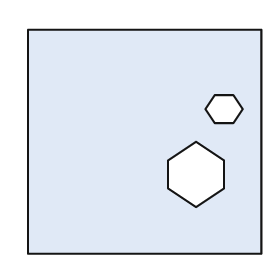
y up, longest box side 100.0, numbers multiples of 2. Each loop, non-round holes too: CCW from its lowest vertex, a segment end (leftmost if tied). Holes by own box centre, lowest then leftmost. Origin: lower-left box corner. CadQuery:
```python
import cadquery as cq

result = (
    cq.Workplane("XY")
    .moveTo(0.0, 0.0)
    .lineTo(100.0, 0.0)
    .lineTo(100.0, 96.0)
    .lineTo(0.0, 96.0)
    .close()
    .moveTo(72.0, 20.0)
    .lineTo(84.0, 28.0)
    .lineTo(84.0, 40.0)
    .lineTo(72.0, 48.0)
    .lineTo(60.0, 40.0)
    .lineTo(60.0, 28.0)
    .close()
    .moveTo(80.0, 56.0)
    .lineTo(88.0, 56.0)
    .lineTo(92.0, 62.0)
    .lineTo(88.0, 68.0)
    .lineTo(80.0, 68.0)
    .lineTo(76.0, 62.0)
    .close()
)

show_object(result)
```